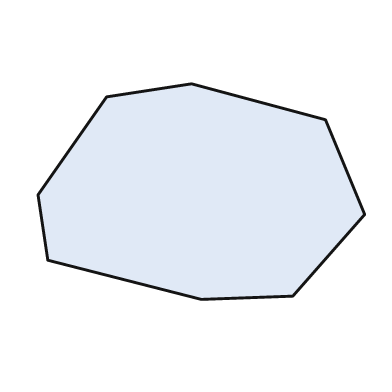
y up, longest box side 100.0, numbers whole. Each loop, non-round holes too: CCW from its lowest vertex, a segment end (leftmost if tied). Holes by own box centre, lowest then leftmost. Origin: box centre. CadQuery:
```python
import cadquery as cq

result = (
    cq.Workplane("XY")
    .moveTo(0.0, -33.0)
    .lineTo(28.0, -32.0)
    .lineTo(50.0, -7.0)
    .lineTo(38.0, 22.0)
    .lineTo(-3.0, 33.0)
    .lineTo(-29.0, 29.0)
    .lineTo(-50.0, -1.0)
    .lineTo(-47.0, -21.0)
    .close()
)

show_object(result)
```